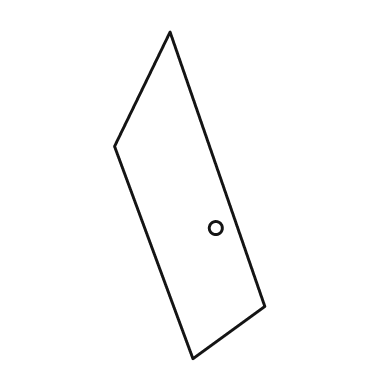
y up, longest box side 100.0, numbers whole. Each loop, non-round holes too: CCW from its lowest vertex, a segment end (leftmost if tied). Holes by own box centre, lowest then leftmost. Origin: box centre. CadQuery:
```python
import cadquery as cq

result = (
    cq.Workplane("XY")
    .moveTo(1.0, -50.0)
    .lineTo(23.0, -34.0)
    .lineTo(-6.0, 50.0)
    .lineTo(-23.0, 15.0)
    .close()
    .moveTo(8.0, -10.0)
    .circle(2.0)
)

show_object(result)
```